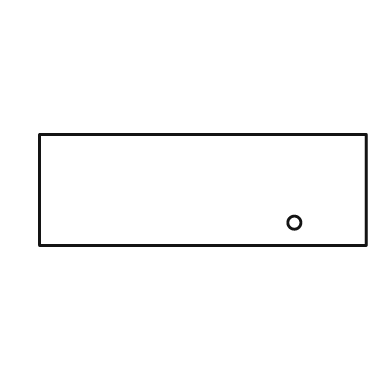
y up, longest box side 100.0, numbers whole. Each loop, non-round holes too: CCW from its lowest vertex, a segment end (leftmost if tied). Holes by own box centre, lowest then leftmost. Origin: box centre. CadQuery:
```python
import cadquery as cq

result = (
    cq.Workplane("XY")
    .moveTo(-50.0, -17.0)
    .lineTo(50.0, -17.0)
    .lineTo(50.0, 17.0)
    .lineTo(-50.0, 17.0)
    .close()
    .moveTo(28.0, -10.0)
    .circle(2.0)
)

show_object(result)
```